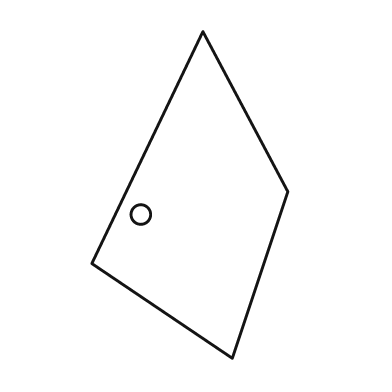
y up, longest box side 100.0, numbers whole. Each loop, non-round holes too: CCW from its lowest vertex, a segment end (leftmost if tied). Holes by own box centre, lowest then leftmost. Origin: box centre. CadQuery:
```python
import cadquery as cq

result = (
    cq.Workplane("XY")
    .moveTo(13.0, -50.0)
    .lineTo(30.0, 1.0)
    .lineTo(4.0, 50.0)
    .lineTo(-30.0, -21.0)
    .close()
    .moveTo(-15.0, -6.0)
    .circle(3.0)
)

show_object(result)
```